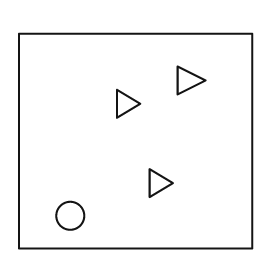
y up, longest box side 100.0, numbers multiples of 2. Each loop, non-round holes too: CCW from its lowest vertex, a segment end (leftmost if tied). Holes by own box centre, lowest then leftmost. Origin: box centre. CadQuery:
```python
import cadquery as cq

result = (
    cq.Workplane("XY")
    .moveTo(-50.0, -46.0)
    .lineTo(50.0, -46.0)
    .lineTo(50.0, 46.0)
    .lineTo(-50.0, 46.0)
    .close()
    .moveTo(-28.0, -32.0)
    .circle(6.0)
    .moveTo(6.0, -24.0)
    .lineTo(16.0, -18.0)
    .lineTo(6.0, -12.0)
    .close()
    .moveTo(-8.0, 10.0)
    .lineTo(2.0, 16.0)
    .lineTo(-8.0, 22.0)
    .close()
    .moveTo(18.0, 20.0)
    .lineTo(30.0, 26.0)
    .lineTo(18.0, 32.0)
    .close()
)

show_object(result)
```